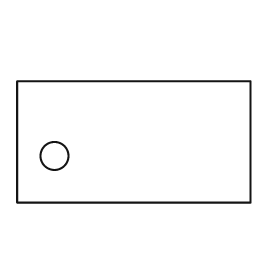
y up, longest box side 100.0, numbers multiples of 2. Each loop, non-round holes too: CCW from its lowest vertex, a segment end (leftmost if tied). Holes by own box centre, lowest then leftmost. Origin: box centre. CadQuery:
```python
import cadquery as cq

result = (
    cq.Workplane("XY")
    .moveTo(-50.0, -26.0)
    .lineTo(50.0, -26.0)
    .lineTo(50.0, 26.0)
    .lineTo(-50.0, 26.0)
    .close()
    .moveTo(-34.0, -6.0)
    .circle(6.0)
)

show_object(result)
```